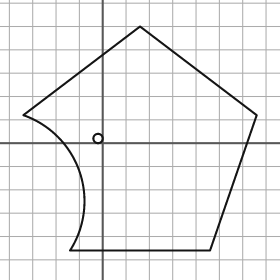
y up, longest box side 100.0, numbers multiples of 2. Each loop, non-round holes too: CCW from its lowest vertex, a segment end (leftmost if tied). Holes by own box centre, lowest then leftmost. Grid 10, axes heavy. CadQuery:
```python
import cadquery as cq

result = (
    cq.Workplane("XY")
    .moveTo(-14.0, -46.0)
    .lineTo(46.0, -46.0)
    .lineTo(66.0, 12.0)
    .lineTo(16.0, 50.0)
    .lineTo(-34.0, 12.0)
    .threePointArc((-10.0, -12.0), (-14.0, -46.0))
    .close()
    .moveTo(-2.0, 2.0)
    .circle(2.0)
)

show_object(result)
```